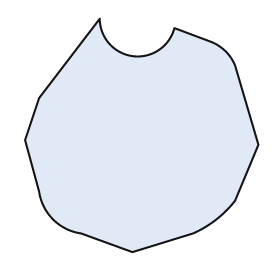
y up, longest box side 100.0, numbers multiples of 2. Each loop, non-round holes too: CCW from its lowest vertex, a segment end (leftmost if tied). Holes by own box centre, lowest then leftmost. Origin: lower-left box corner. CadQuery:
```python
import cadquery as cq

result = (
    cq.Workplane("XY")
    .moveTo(46.0, 0.0)
    .lineTo(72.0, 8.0)
    .threePointArc((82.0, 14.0), (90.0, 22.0))
    .lineTo(100.0, 46.0)
    .lineTo(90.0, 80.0)
    .threePointArc((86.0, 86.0), (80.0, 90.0))
    .lineTo(64.0, 96.0)
    .threePointArc((46.0, 84.0), (32.0, 100.0))
    .lineTo(6.0, 66.0)
    .lineTo(0.0, 48.0)
    .lineTo(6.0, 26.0)
    .threePointArc((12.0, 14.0), (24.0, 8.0))
    .close()
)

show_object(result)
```